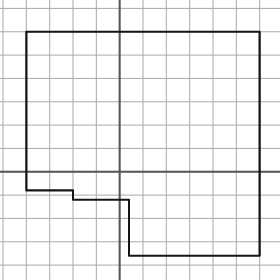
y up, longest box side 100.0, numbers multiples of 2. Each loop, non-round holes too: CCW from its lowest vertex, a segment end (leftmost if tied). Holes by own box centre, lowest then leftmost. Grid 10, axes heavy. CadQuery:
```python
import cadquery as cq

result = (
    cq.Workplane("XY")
    .moveTo(4.0, -36.0)
    .lineTo(60.0, -36.0)
    .lineTo(60.0, 60.0)
    .lineTo(-40.0, 60.0)
    .lineTo(-40.0, -8.0)
    .lineTo(-20.0, -8.0)
    .lineTo(-20.0, -12.0)
    .lineTo(4.0, -12.0)
    .close()
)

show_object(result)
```